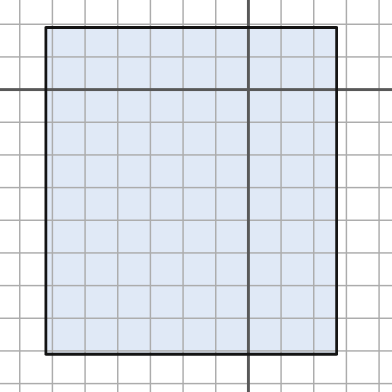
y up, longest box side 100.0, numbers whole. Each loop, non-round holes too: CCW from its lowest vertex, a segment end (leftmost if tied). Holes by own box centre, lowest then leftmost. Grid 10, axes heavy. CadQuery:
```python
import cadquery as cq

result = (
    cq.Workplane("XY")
    .moveTo(-62.0, -81.0)
    .lineTo(27.0, -81.0)
    .lineTo(27.0, 19.0)
    .lineTo(-62.0, 19.0)
    .close()
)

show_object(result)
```